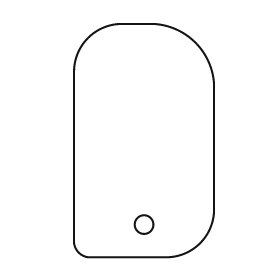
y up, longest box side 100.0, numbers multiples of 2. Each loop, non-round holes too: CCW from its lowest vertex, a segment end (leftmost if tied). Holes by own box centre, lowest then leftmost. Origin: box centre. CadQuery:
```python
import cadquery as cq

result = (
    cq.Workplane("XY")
    .moveTo(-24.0, -50.0)
    .lineTo(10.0, -50.0)
    .threePointArc((24.0, -44.0), (30.0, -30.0))
    .lineTo(30.0, 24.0)
    .threePointArc((22.0, 42.0), (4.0, 50.0))
    .lineTo(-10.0, 50.0)
    .threePointArc((-24.0, 44.0), (-30.0, 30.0))
    .lineTo(-30.0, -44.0)
    .threePointArc((-28.0, -48.0), (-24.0, -50.0))
    .close()
    .moveTo(0.0, -36.0)
    .circle(4.0)
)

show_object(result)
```